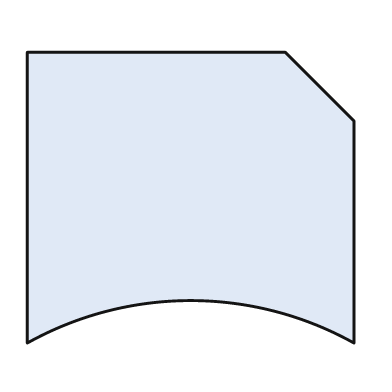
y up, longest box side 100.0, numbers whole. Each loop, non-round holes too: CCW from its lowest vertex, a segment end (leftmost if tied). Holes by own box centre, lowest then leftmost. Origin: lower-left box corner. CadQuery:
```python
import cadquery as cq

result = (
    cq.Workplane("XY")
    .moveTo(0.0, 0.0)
    .threePointArc((50.0, 13.0), (100.0, 0.0))
    .lineTo(100.0, 68.0)
    .lineTo(79.0, 89.0)
    .lineTo(0.0, 89.0)
    .close()
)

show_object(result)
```